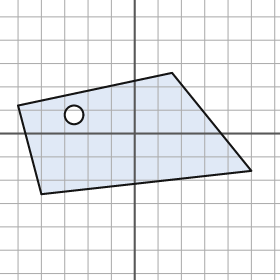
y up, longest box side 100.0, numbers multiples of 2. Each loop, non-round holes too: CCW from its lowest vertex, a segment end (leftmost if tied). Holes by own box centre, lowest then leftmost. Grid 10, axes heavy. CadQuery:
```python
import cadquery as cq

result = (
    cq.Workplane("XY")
    .moveTo(-40.0, -26.0)
    .lineTo(50.0, -16.0)
    .lineTo(16.0, 26.0)
    .lineTo(-50.0, 12.0)
    .close()
    .moveTo(-26.0, 8.0)
    .circle(4.0)
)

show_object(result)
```